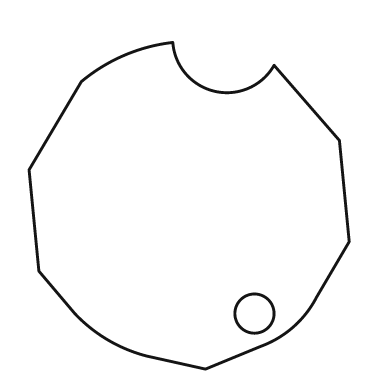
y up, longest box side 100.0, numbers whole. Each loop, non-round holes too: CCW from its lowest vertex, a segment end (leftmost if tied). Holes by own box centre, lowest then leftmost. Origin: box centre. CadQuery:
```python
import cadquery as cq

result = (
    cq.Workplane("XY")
    .moveTo(5.0, -50.0)
    .lineTo(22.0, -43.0)
    .threePointArc((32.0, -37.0), (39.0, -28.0))
    .lineTo(49.0, -11.0)
    .lineTo(46.0, 20.0)
    .lineTo(26.0, 43.0)
    .threePointArc((8.0, 35.0), (-5.0, 50.0))
    .threePointArc((-20.0, 46.0), (-33.0, 38.0))
    .lineTo(-49.0, 11.0)
    .lineTo(-46.0, -20.0)
    .lineTo(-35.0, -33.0)
    .threePointArc((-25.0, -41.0), (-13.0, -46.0))
    .close()
    .moveTo(20.0, -33.0)
    .circle(6.0)
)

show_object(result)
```